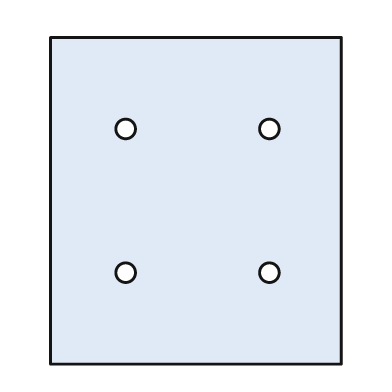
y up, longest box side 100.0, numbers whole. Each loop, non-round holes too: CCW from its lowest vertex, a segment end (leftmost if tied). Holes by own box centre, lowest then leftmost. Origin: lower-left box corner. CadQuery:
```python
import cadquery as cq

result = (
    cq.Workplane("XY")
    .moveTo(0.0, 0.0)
    .lineTo(89.0, 0.0)
    .lineTo(89.0, 100.0)
    .lineTo(0.0, 100.0)
    .close()
    .moveTo(23.0, 28.0)
    .circle(3.0)
    .moveTo(67.0, 28.0)
    .circle(3.0)
    .moveTo(23.0, 72.0)
    .circle(3.0)
    .moveTo(67.0, 72.0)
    .circle(3.0)
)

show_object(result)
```